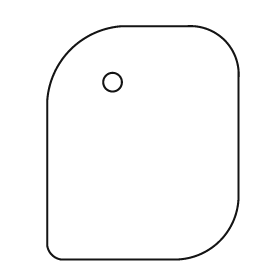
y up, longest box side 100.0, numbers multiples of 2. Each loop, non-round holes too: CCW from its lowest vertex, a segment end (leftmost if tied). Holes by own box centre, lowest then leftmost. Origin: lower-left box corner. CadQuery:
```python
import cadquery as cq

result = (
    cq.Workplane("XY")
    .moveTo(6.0, 0.0)
    .lineTo(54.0, 0.0)
    .threePointArc((74.0, 8.0), (82.0, 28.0))
    .lineTo(82.0, 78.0)
    .threePointArc((76.0, 94.0), (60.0, 100.0))
    .lineTo(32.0, 100.0)
    .threePointArc((10.0, 90.0), (0.0, 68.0))
    .lineTo(0.0, 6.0)
    .threePointArc((2.0, 2.0), (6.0, 0.0))
    .close()
    .moveTo(28.0, 76.0)
    .circle(4.0)
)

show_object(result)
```